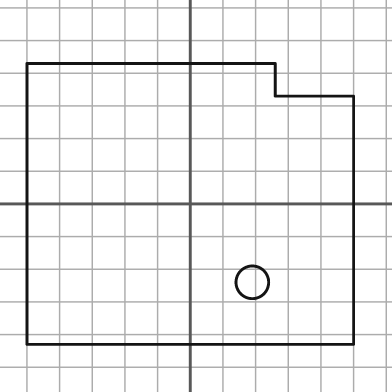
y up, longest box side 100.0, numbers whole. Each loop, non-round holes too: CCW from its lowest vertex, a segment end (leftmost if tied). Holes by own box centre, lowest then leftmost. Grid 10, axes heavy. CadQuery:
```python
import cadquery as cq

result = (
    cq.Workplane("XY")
    .moveTo(-50.0, -43.0)
    .lineTo(50.0, -43.0)
    .lineTo(50.0, 33.0)
    .lineTo(26.0, 33.0)
    .lineTo(26.0, 43.0)
    .lineTo(-50.0, 43.0)
    .close()
    .moveTo(19.0, -24.0)
    .circle(5.0)
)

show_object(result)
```